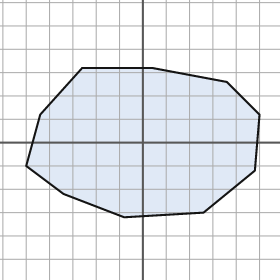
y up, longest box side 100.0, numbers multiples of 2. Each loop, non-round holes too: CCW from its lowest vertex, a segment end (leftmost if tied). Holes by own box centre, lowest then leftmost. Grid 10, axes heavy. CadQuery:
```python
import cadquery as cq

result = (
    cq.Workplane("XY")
    .moveTo(-8.0, -32.0)
    .lineTo(26.0, -30.0)
    .lineTo(48.0, -12.0)
    .lineTo(50.0, 12.0)
    .lineTo(36.0, 26.0)
    .lineTo(4.0, 32.0)
    .lineTo(-26.0, 32.0)
    .lineTo(-44.0, 12.0)
    .lineTo(-50.0, -10.0)
    .lineTo(-34.0, -22.0)
    .close()
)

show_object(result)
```